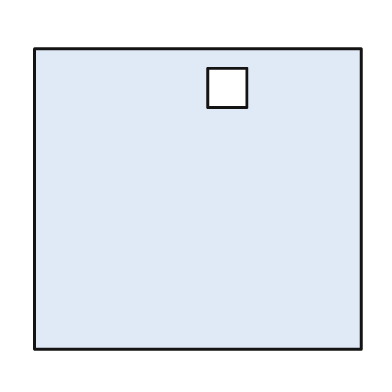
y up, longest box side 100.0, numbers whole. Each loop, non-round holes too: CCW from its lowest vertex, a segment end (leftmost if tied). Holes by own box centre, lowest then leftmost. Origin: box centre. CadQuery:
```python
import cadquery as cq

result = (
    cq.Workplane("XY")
    .moveTo(-50.0, -46.0)
    .lineTo(50.0, -46.0)
    .lineTo(50.0, 46.0)
    .lineTo(-50.0, 46.0)
    .close()
    .moveTo(3.0, 28.0)
    .lineTo(15.0, 28.0)
    .lineTo(15.0, 40.0)
    .lineTo(3.0, 40.0)
    .close()
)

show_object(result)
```